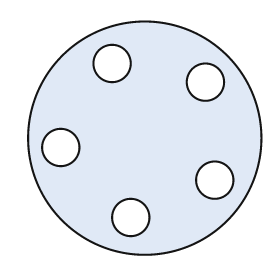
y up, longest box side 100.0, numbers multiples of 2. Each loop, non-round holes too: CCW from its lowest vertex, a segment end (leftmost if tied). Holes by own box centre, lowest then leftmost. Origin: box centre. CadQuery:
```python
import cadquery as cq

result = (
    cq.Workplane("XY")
    .moveTo(0.0, 0.0)
    .circle(50.0)
    .moveTo(-6.0, -34.0)
    .circle(8.0)
    .moveTo(30.0, -18.0)
    .circle(8.0)
    .moveTo(-36.0, -4.0)
    .circle(8.0)
    .moveTo(26.0, 24.0)
    .circle(8.0)
    .moveTo(-14.0, 32.0)
    .circle(8.0)
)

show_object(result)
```